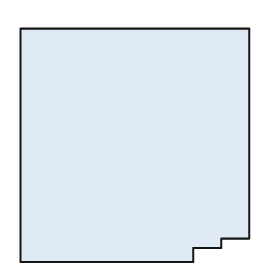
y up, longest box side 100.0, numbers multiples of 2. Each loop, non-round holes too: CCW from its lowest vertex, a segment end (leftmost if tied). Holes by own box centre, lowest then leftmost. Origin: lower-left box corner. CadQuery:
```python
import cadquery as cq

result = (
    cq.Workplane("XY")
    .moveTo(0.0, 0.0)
    .lineTo(74.0, 0.0)
    .lineTo(74.0, 6.0)
    .lineTo(86.0, 6.0)
    .lineTo(86.0, 10.0)
    .lineTo(98.0, 10.0)
    .lineTo(98.0, 100.0)
    .lineTo(0.0, 100.0)
    .close()
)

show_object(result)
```